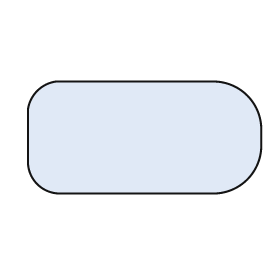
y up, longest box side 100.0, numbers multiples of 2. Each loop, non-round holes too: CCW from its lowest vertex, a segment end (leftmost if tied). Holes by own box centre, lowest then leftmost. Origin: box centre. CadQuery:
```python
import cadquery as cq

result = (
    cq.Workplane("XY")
    .moveTo(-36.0, -24.0)
    .lineTo(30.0, -24.0)
    .threePointArc((44.0, -18.0), (50.0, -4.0))
    .lineTo(50.0, 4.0)
    .threePointArc((44.0, 18.0), (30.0, 24.0))
    .lineTo(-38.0, 24.0)
    .threePointArc((-46.0, 20.0), (-50.0, 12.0))
    .lineTo(-50.0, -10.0)
    .threePointArc((-46.0, -20.0), (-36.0, -24.0))
    .close()
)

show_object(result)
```